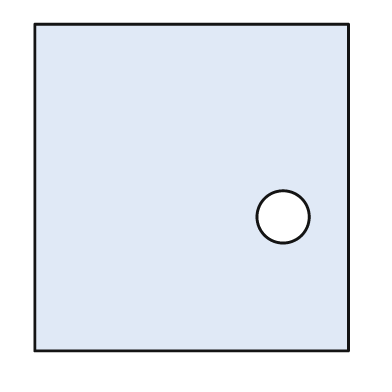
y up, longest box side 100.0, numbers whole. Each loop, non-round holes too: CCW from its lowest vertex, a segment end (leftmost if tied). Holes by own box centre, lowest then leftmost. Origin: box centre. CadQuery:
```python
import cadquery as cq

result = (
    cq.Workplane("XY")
    .moveTo(-48.0, -50.0)
    .lineTo(48.0, -50.0)
    .lineTo(48.0, 50.0)
    .lineTo(-48.0, 50.0)
    .close()
    .moveTo(28.0, -9.0)
    .circle(8.0)
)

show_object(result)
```